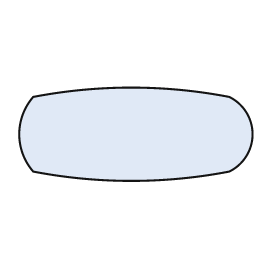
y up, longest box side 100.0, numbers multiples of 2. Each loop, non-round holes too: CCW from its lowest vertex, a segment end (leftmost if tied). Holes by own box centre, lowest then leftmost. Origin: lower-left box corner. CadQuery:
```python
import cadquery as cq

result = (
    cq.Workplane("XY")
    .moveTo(6.0, 4.0)
    .threePointArc((48.0, 0.0), (90.0, 4.0))
    .threePointArc((100.0, 20.0), (90.0, 36.0))
    .threePointArc((48.0, 40.0), (6.0, 36.0))
    .threePointArc((0.0, 20.0), (6.0, 4.0))
    .close()
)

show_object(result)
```